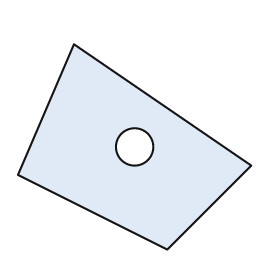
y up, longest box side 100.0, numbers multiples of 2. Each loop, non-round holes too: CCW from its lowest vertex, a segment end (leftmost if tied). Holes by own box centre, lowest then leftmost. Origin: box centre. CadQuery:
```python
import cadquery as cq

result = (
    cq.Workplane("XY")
    .moveTo(14.0, -44.0)
    .lineTo(50.0, -8.0)
    .lineTo(-26.0, 44.0)
    .lineTo(-50.0, -12.0)
    .close()
    .moveTo(0.0, 0.0)
    .circle(8.0)
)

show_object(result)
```